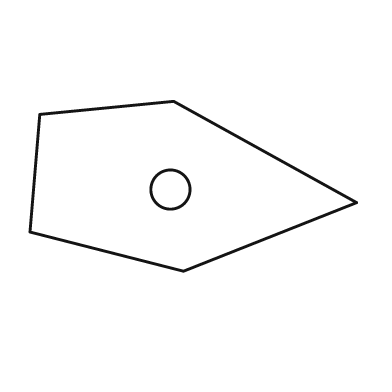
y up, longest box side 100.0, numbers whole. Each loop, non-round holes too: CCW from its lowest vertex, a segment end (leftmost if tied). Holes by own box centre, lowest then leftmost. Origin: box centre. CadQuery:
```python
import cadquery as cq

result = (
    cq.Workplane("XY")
    .moveTo(-3.0, -26.0)
    .lineTo(50.0, -5.0)
    .lineTo(-6.0, 26.0)
    .lineTo(-47.0, 22.0)
    .lineTo(-50.0, -14.0)
    .close()
    .moveTo(-7.0, -1.0)
    .circle(6.0)
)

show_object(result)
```